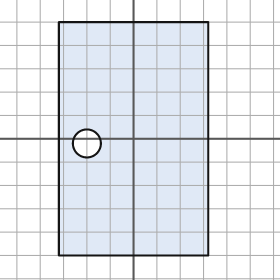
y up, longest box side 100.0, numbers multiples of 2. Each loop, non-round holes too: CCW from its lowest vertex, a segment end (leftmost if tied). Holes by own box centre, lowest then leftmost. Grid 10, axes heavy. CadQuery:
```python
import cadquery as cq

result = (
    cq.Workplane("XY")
    .moveTo(-32.0, -50.0)
    .lineTo(32.0, -50.0)
    .lineTo(32.0, 50.0)
    .lineTo(-32.0, 50.0)
    .close()
    .moveTo(-20.0, -2.0)
    .circle(6.0)
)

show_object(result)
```